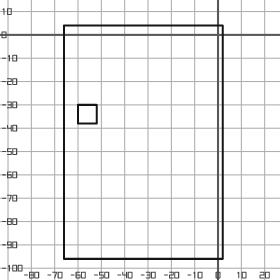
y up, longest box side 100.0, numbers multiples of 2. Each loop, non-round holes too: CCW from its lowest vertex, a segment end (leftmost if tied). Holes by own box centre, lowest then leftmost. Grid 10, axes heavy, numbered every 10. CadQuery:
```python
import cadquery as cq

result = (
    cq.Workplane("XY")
    .moveTo(-66.0, -96.0)
    .lineTo(2.0, -96.0)
    .lineTo(2.0, 4.0)
    .lineTo(-66.0, 4.0)
    .close()
    .moveTo(-60.0, -38.0)
    .lineTo(-52.0, -38.0)
    .lineTo(-52.0, -30.0)
    .lineTo(-60.0, -30.0)
    .close()
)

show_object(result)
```